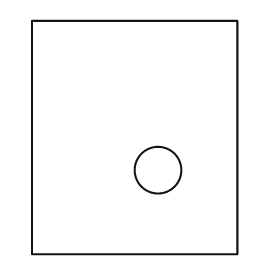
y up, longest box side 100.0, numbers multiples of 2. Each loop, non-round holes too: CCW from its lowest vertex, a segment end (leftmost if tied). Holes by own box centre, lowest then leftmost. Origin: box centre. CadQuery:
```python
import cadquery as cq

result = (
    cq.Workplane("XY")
    .moveTo(-44.0, -50.0)
    .lineTo(44.0, -50.0)
    .lineTo(44.0, 50.0)
    .lineTo(-44.0, 50.0)
    .close()
    .moveTo(10.0, -14.0)
    .circle(10.0)
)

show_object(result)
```